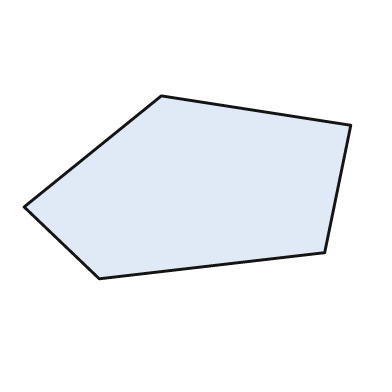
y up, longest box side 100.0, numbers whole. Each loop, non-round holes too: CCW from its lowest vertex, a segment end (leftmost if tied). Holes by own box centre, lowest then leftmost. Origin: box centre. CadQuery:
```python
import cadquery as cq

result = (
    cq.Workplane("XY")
    .moveTo(-27.0, -28.0)
    .lineTo(42.0, -20.0)
    .lineTo(50.0, 19.0)
    .lineTo(-8.0, 28.0)
    .lineTo(-50.0, -6.0)
    .close()
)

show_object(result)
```